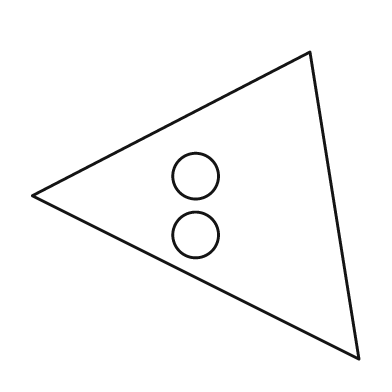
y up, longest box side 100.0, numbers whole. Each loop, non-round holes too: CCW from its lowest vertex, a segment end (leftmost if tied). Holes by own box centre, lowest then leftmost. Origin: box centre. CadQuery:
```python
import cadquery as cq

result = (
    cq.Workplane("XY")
    .moveTo(50.0, -47.0)
    .lineTo(35.0, 47.0)
    .lineTo(-50.0, 3.0)
    .close()
    .moveTo(0.0, -9.0)
    .circle(7.0)
    .moveTo(0.0, 9.0)
    .circle(7.0)
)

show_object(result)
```